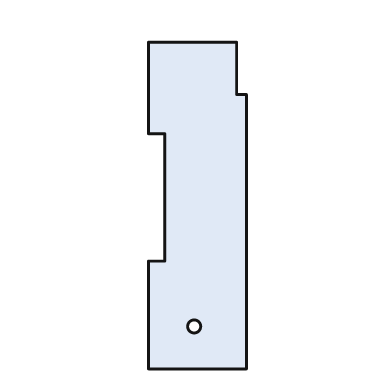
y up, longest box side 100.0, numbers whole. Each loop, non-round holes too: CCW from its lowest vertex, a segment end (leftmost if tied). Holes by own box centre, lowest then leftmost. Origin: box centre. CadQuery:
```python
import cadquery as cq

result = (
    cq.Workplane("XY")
    .moveTo(-15.0, -50.0)
    .lineTo(15.0, -50.0)
    .lineTo(15.0, 34.0)
    .lineTo(12.0, 34.0)
    .lineTo(12.0, 50.0)
    .lineTo(-15.0, 50.0)
    .lineTo(-15.0, 22.0)
    .lineTo(-10.0, 22.0)
    .lineTo(-10.0, -17.0)
    .lineTo(-15.0, -17.0)
    .close()
    .moveTo(-1.0, -37.0)
    .circle(2.0)
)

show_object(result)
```